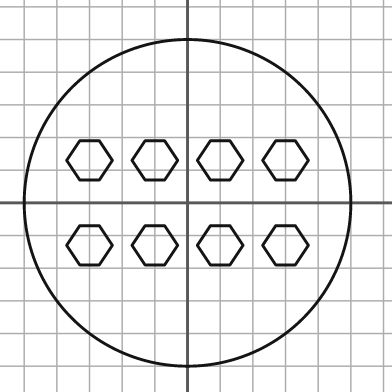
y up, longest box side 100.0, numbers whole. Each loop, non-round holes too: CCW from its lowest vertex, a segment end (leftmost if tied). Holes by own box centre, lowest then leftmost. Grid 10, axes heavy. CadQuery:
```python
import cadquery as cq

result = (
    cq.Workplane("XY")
    .moveTo(0.0, 0.0)
    .circle(50.0)
    .moveTo(-33.0, -19.0)
    .lineTo(-27.0, -19.0)
    .lineTo(-23.0, -13.0)
    .lineTo(-27.0, -7.0)
    .lineTo(-33.0, -7.0)
    .lineTo(-37.0, -13.0)
    .close()
    .moveTo(-13.0, -19.0)
    .lineTo(-7.0, -19.0)
    .lineTo(-3.0, -13.0)
    .lineTo(-7.0, -7.0)
    .lineTo(-13.0, -7.0)
    .lineTo(-17.0, -13.0)
    .close()
    .moveTo(7.0, -19.0)
    .lineTo(13.0, -19.0)
    .lineTo(17.0, -13.0)
    .lineTo(13.0, -7.0)
    .lineTo(7.0, -7.0)
    .lineTo(3.0, -13.0)
    .close()
    .moveTo(27.0, -19.0)
    .lineTo(33.0, -19.0)
    .lineTo(37.0, -13.0)
    .lineTo(33.0, -7.0)
    .lineTo(27.0, -7.0)
    .lineTo(23.0, -13.0)
    .close()
    .moveTo(-33.0, 7.0)
    .lineTo(-27.0, 7.0)
    .lineTo(-23.0, 13.0)
    .lineTo(-27.0, 19.0)
    .lineTo(-33.0, 19.0)
    .lineTo(-37.0, 13.0)
    .close()
    .moveTo(-13.0, 7.0)
    .lineTo(-7.0, 7.0)
    .lineTo(-3.0, 13.0)
    .lineTo(-7.0, 19.0)
    .lineTo(-13.0, 19.0)
    .lineTo(-17.0, 13.0)
    .close()
    .moveTo(7.0, 7.0)
    .lineTo(13.0, 7.0)
    .lineTo(17.0, 13.0)
    .lineTo(13.0, 19.0)
    .lineTo(7.0, 19.0)
    .lineTo(3.0, 13.0)
    .close()
    .moveTo(27.0, 7.0)
    .lineTo(33.0, 7.0)
    .lineTo(37.0, 13.0)
    .lineTo(33.0, 19.0)
    .lineTo(27.0, 19.0)
    .lineTo(23.0, 13.0)
    .close()
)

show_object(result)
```